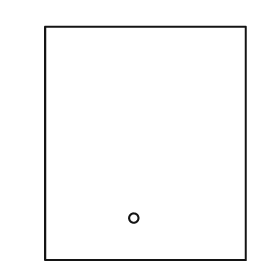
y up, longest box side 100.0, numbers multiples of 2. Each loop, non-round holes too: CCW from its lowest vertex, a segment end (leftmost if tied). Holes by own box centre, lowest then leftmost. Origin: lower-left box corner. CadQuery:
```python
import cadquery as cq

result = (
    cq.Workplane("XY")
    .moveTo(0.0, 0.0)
    .lineTo(86.0, 0.0)
    .lineTo(86.0, 100.0)
    .lineTo(0.0, 100.0)
    .close()
    .moveTo(38.0, 18.0)
    .circle(2.0)
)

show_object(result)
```